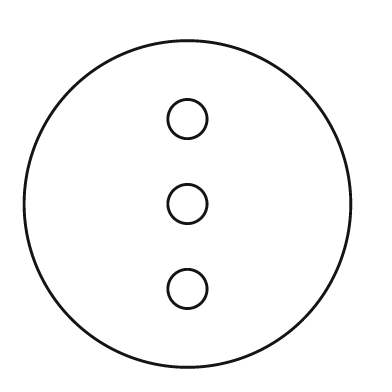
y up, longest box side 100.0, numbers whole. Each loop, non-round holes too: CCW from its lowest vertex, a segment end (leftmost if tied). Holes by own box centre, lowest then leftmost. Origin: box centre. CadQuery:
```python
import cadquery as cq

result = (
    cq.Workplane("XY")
    .moveTo(0.0, 0.0)
    .circle(50.0)
    .moveTo(0.0, -26.0)
    .circle(6.0)
    .moveTo(0.0, 0.0)
    .circle(6.0)
    .moveTo(0.0, 26.0)
    .circle(6.0)
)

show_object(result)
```